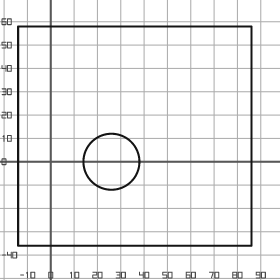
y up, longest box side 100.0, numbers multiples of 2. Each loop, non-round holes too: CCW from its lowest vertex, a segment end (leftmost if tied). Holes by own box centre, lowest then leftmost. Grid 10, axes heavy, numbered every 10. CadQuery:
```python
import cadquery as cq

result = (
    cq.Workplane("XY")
    .moveTo(-14.0, -36.0)
    .lineTo(86.0, -36.0)
    .lineTo(86.0, 58.0)
    .lineTo(-14.0, 58.0)
    .close()
    .moveTo(26.0, 0.0)
    .circle(12.0)
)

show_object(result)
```